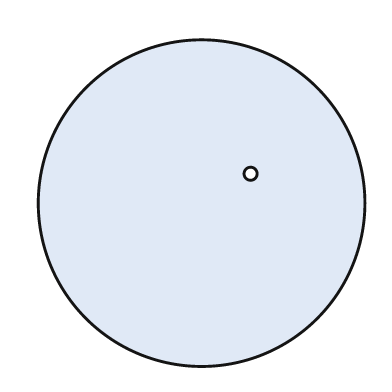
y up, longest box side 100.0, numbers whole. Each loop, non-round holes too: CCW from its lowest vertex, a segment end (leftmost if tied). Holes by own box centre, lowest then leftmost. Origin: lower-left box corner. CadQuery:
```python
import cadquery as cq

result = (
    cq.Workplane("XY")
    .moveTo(50.0, 50.0)
    .circle(50.0)
    .moveTo(65.0, 59.0)
    .circle(2.0)
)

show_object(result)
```